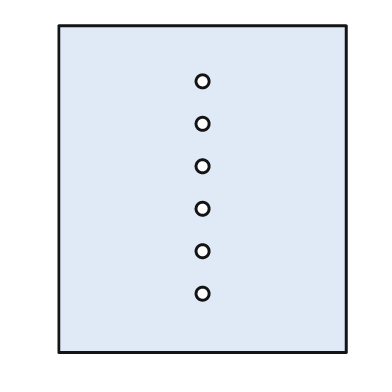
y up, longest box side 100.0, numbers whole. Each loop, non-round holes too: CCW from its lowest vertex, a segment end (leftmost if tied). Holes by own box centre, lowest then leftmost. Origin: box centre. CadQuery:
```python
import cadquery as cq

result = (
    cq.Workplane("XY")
    .moveTo(-44.0, -50.0)
    .lineTo(44.0, -50.0)
    .lineTo(44.0, 50.0)
    .lineTo(-44.0, 50.0)
    .close()
    .moveTo(0.0, -32.0)
    .circle(2.0)
    .moveTo(0.0, -19.0)
    .circle(2.0)
    .moveTo(0.0, -6.0)
    .circle(2.0)
    .moveTo(0.0, 7.0)
    .circle(2.0)
    .moveTo(0.0, 20.0)
    .circle(2.0)
    .moveTo(0.0, 33.0)
    .circle(2.0)
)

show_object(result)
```